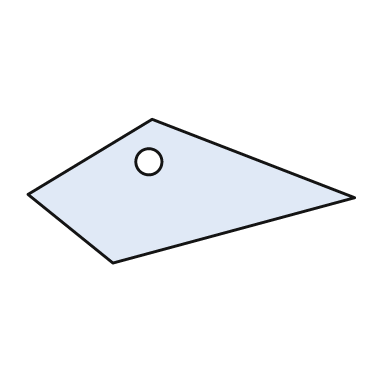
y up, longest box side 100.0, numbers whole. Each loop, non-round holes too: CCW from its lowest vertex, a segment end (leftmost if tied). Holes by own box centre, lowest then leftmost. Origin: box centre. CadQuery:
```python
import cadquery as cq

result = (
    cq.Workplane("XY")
    .moveTo(-24.0, -22.0)
    .lineTo(50.0, -2.0)
    .lineTo(-12.0, 22.0)
    .lineTo(-50.0, -1.0)
    .close()
    .moveTo(-13.0, 9.0)
    .circle(4.0)
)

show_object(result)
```